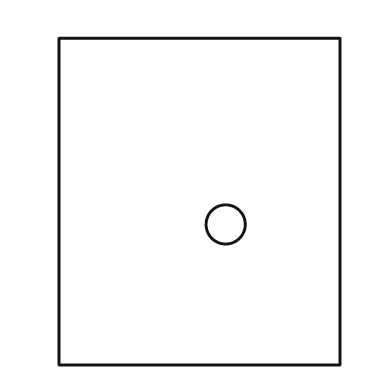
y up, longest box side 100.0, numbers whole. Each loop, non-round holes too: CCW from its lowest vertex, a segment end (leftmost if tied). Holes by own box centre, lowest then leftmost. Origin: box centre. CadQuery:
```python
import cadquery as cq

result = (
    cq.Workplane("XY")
    .moveTo(-43.0, -50.0)
    .lineTo(43.0, -50.0)
    .lineTo(43.0, 50.0)
    .lineTo(-43.0, 50.0)
    .close()
    .moveTo(8.0, -7.0)
    .circle(6.0)
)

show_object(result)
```